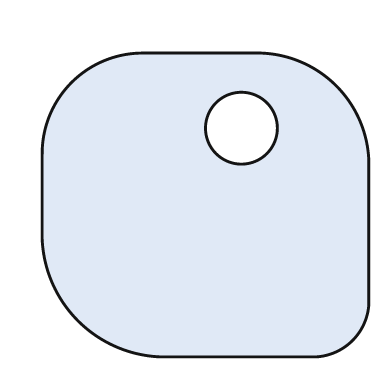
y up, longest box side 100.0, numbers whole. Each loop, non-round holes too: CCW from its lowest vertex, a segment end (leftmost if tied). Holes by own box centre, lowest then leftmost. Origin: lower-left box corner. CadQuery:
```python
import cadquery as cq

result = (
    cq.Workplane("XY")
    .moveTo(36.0, 0.0)
    .lineTo(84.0, 0.0)
    .threePointArc((95.0, 5.0), (100.0, 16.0))
    .lineTo(100.0, 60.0)
    .threePointArc((90.0, 83.0), (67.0, 93.0))
    .lineTo(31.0, 93.0)
    .threePointArc((9.0, 84.0), (0.0, 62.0))
    .lineTo(0.0, 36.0)
    .threePointArc((11.0, 11.0), (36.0, 0.0))
    .close()
    .moveTo(61.0, 70.0)
    .circle(11.0)
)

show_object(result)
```